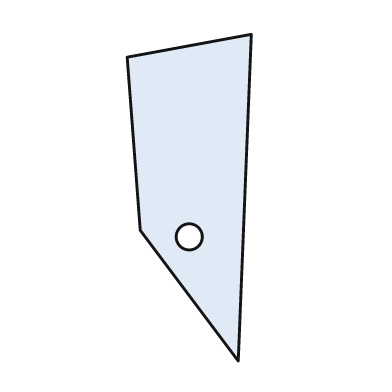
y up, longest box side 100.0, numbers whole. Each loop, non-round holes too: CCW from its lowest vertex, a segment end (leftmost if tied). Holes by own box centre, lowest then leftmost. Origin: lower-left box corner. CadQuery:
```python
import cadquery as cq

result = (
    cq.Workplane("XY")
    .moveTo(34.0, 0.0)
    .lineTo(38.0, 100.0)
    .lineTo(0.0, 93.0)
    .lineTo(4.0, 40.0)
    .close()
    .moveTo(19.0, 38.0)
    .circle(4.0)
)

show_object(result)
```